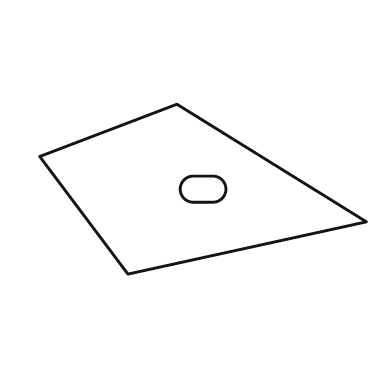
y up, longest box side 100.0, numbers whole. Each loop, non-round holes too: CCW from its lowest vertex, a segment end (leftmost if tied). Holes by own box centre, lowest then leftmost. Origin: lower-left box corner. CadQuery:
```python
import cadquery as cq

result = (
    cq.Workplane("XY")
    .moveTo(27.0, 0.0)
    .lineTo(100.0, 16.0)
    .lineTo(42.0, 52.0)
    .lineTo(0.0, 36.0)
    .close()
    .moveTo(47.0, 22.0)
    .lineTo(53.0, 22.0)
    .threePointArc((57.0, 26.0), (53.0, 30.0))
    .lineTo(47.0, 30.0)
    .threePointArc((43.0, 26.0), (47.0, 22.0))
    .close()
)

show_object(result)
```